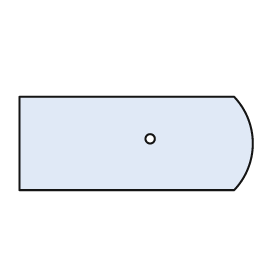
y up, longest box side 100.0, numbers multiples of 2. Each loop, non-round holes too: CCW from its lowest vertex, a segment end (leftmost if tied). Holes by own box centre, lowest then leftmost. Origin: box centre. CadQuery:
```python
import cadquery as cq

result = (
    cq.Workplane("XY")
    .moveTo(-50.0, -20.0)
    .lineTo(42.0, -20.0)
    .threePointArc((50.0, 0.0), (42.0, 20.0))
    .lineTo(-50.0, 20.0)
    .close()
    .moveTo(6.0, 2.0)
    .circle(2.0)
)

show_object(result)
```